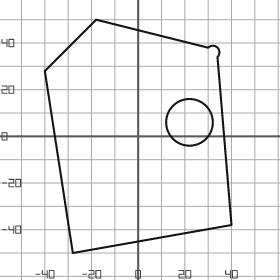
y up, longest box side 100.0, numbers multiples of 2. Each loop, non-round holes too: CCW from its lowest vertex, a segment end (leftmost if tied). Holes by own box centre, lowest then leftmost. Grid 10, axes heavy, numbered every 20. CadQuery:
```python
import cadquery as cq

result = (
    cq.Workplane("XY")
    .moveTo(-28.0, -50.0)
    .lineTo(40.0, -38.0)
    .lineTo(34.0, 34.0)
    .threePointArc((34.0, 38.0), (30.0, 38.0))
    .lineTo(-18.0, 50.0)
    .lineTo(-40.0, 28.0)
    .close()
    .moveTo(22.0, 6.0)
    .circle(10.0)
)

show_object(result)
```